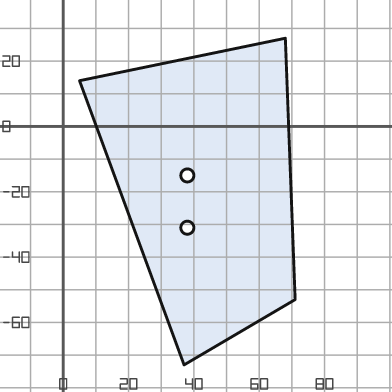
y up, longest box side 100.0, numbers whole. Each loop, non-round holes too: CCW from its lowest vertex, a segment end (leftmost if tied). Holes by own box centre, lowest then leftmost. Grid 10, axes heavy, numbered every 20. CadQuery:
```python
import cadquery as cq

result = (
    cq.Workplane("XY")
    .moveTo(37.0, -73.0)
    .lineTo(71.0, -53.0)
    .lineTo(68.0, 27.0)
    .lineTo(5.0, 14.0)
    .close()
    .moveTo(38.0, -31.0)
    .circle(2.0)
    .moveTo(38.0, -15.0)
    .circle(2.0)
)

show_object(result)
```